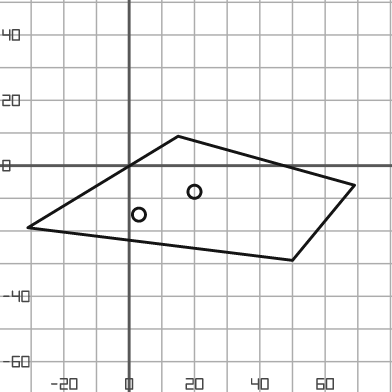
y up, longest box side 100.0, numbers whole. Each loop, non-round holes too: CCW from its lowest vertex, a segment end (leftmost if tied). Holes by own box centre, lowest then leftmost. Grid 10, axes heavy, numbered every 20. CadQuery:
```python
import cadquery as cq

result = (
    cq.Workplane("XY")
    .moveTo(50.0, -29.0)
    .lineTo(69.0, -6.0)
    .lineTo(15.0, 9.0)
    .lineTo(-31.0, -19.0)
    .close()
    .moveTo(3.0, -15.0)
    .circle(2.0)
    .moveTo(20.0, -8.0)
    .circle(2.0)
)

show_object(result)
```